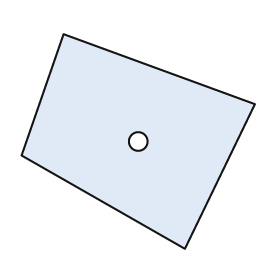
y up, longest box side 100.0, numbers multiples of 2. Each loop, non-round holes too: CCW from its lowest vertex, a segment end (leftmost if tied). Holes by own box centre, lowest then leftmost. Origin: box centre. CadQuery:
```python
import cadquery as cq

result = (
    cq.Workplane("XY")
    .moveTo(20.0, -46.0)
    .lineTo(50.0, 16.0)
    .lineTo(-32.0, 46.0)
    .lineTo(-50.0, -6.0)
    .close()
    .moveTo(0.0, 0.0)
    .circle(4.0)
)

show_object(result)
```